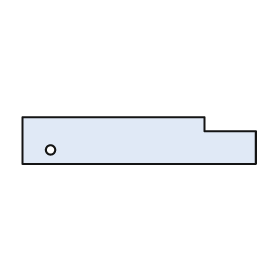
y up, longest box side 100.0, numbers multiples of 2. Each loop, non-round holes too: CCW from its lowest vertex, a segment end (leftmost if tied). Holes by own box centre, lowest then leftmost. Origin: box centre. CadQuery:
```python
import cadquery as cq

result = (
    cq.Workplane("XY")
    .moveTo(-50.0, -10.0)
    .lineTo(50.0, -10.0)
    .lineTo(50.0, 4.0)
    .lineTo(28.0, 4.0)
    .lineTo(28.0, 10.0)
    .lineTo(-50.0, 10.0)
    .close()
    .moveTo(-38.0, -4.0)
    .circle(2.0)
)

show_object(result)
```